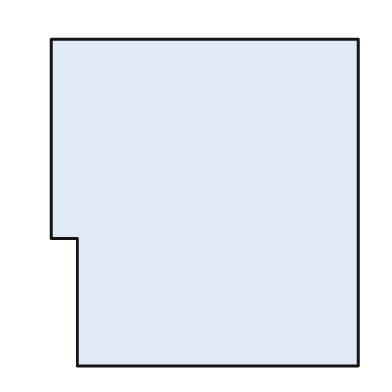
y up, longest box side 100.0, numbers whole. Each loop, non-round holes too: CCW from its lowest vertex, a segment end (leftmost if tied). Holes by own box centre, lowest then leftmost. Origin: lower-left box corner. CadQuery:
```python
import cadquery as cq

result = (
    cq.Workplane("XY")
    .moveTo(8.0, 0.0)
    .lineTo(94.0, 0.0)
    .lineTo(94.0, 100.0)
    .lineTo(0.0, 100.0)
    .lineTo(0.0, 39.0)
    .lineTo(8.0, 39.0)
    .close()
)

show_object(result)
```